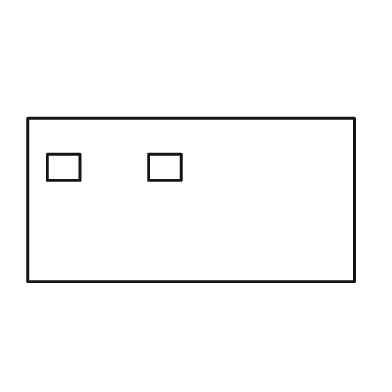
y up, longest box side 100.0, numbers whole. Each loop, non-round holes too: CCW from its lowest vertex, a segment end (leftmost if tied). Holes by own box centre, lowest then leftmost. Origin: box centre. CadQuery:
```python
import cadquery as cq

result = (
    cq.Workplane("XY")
    .moveTo(-50.0, -25.0)
    .lineTo(50.0, -25.0)
    .lineTo(50.0, 25.0)
    .lineTo(-50.0, 25.0)
    .close()
    .moveTo(-44.0, 6.0)
    .lineTo(-34.0, 6.0)
    .lineTo(-34.0, 14.0)
    .lineTo(-44.0, 14.0)
    .close()
    .moveTo(-13.0, 6.0)
    .lineTo(-3.0, 6.0)
    .lineTo(-3.0, 14.0)
    .lineTo(-13.0, 14.0)
    .close()
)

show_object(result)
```